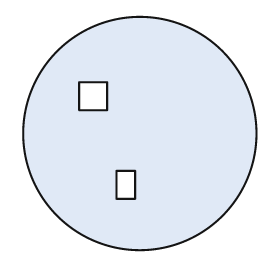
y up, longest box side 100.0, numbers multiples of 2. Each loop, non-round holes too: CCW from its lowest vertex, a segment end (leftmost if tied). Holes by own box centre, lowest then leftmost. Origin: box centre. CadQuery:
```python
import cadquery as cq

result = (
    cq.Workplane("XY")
    .moveTo(0.0, 0.0)
    .circle(50.0)
    .moveTo(-10.0, -28.0)
    .lineTo(-2.0, -28.0)
    .lineTo(-2.0, -16.0)
    .lineTo(-10.0, -16.0)
    .close()
    .moveTo(-26.0, 10.0)
    .lineTo(-14.0, 10.0)
    .lineTo(-14.0, 22.0)
    .lineTo(-26.0, 22.0)
    .close()
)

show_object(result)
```